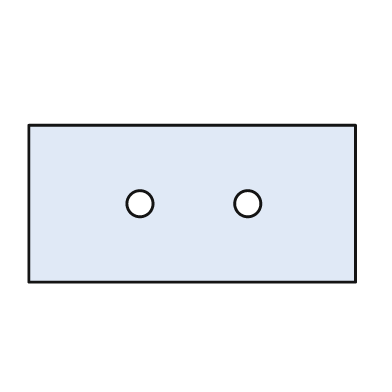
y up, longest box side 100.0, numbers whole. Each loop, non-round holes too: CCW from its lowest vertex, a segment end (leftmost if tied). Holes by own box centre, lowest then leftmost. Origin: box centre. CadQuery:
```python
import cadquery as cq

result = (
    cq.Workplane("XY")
    .moveTo(-50.0, -24.0)
    .lineTo(50.0, -24.0)
    .lineTo(50.0, 24.0)
    .lineTo(-50.0, 24.0)
    .close()
    .moveTo(-16.0, 0.0)
    .circle(4.0)
    .moveTo(17.0, 0.0)
    .circle(4.0)
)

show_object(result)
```